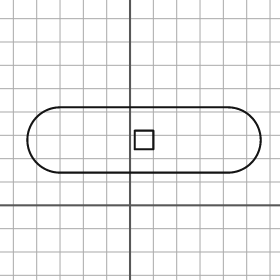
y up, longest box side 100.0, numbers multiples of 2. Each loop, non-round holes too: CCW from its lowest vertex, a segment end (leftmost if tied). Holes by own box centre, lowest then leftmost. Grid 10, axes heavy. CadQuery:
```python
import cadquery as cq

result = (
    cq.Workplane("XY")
    .moveTo(-30.0, 14.0)
    .lineTo(42.0, 14.0)
    .threePointArc((56.0, 28.0), (42.0, 42.0))
    .lineTo(-30.0, 42.0)
    .threePointArc((-44.0, 28.0), (-30.0, 14.0))
    .close()
    .moveTo(2.0, 24.0)
    .lineTo(10.0, 24.0)
    .lineTo(10.0, 32.0)
    .lineTo(2.0, 32.0)
    .close()
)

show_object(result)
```